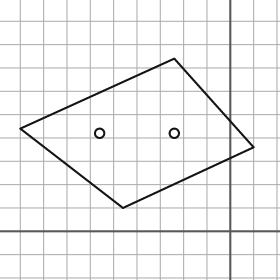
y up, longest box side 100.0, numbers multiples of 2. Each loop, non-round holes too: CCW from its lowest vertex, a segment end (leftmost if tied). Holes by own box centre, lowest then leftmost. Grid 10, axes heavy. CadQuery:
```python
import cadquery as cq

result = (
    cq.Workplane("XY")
    .moveTo(-46.0, 10.0)
    .lineTo(10.0, 36.0)
    .lineTo(-24.0, 74.0)
    .lineTo(-90.0, 44.0)
    .close()
    .moveTo(-56.0, 42.0)
    .circle(2.0)
    .moveTo(-24.0, 42.0)
    .circle(2.0)
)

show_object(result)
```